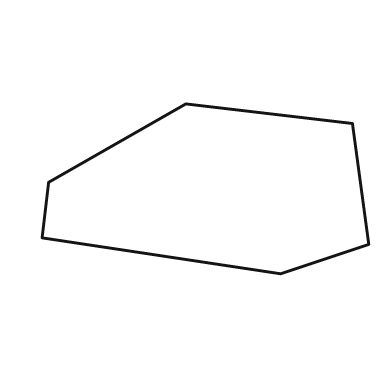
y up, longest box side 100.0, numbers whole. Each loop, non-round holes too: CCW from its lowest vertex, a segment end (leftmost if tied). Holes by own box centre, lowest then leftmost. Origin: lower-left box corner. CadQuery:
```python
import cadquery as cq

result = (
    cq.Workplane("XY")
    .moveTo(73.0, 0.0)
    .lineTo(100.0, 9.0)
    .lineTo(95.0, 46.0)
    .lineTo(44.0, 52.0)
    .lineTo(2.0, 28.0)
    .lineTo(0.0, 11.0)
    .close()
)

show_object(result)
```